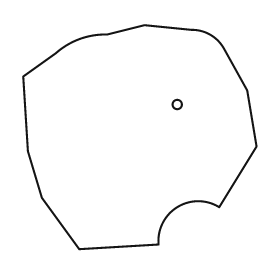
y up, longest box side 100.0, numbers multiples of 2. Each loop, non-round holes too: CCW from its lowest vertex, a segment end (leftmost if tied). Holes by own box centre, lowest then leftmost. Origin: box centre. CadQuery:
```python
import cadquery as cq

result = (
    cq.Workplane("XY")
    .moveTo(-26.0, -48.0)
    .lineTo(8.0, -46.0)
    .threePointArc((16.0, -30.0), (34.0, -30.0))
    .lineTo(50.0, -4.0)
    .lineTo(46.0, 20.0)
    .lineTo(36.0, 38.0)
    .threePointArc((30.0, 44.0), (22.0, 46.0))
    .lineTo(2.0, 48.0)
    .lineTo(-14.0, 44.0)
    .threePointArc((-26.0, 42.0), (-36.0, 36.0))
    .lineTo(-50.0, 26.0)
    .lineTo(-48.0, -6.0)
    .lineTo(-42.0, -26.0)
    .close()
    .moveTo(16.0, 14.0)
    .circle(2.0)
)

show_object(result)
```